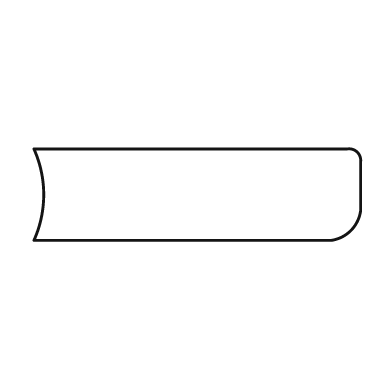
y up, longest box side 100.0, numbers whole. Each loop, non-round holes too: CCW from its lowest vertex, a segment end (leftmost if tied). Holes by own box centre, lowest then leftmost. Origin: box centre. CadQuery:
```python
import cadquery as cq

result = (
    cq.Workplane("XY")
    .moveTo(-50.0, -14.0)
    .lineTo(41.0, -14.0)
    .threePointArc((47.0, -11.0), (50.0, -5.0))
    .lineTo(50.0, 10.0)
    .threePointArc((49.0, 13.0), (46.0, 14.0))
    .lineTo(-50.0, 14.0)
    .threePointArc((-47.0, 0.0), (-50.0, -14.0))
    .close()
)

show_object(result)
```